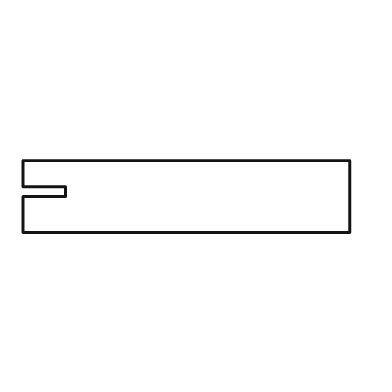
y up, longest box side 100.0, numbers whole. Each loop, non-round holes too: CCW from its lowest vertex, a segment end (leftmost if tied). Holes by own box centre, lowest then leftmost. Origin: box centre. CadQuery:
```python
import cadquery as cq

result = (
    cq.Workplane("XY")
    .moveTo(-50.0, -11.0)
    .lineTo(50.0, -11.0)
    .lineTo(50.0, 11.0)
    .lineTo(-50.0, 11.0)
    .lineTo(-50.0, 3.0)
    .lineTo(-37.0, 3.0)
    .lineTo(-37.0, 0.0)
    .lineTo(-50.0, 0.0)
    .close()
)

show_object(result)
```